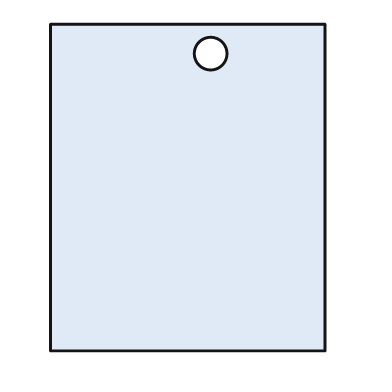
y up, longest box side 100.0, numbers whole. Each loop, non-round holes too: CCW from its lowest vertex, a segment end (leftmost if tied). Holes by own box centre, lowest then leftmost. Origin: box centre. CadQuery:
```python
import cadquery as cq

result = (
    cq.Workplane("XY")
    .moveTo(-42.0, -50.0)
    .lineTo(42.0, -50.0)
    .lineTo(42.0, 50.0)
    .lineTo(-42.0, 50.0)
    .close()
    .moveTo(7.0, 41.0)
    .circle(5.0)
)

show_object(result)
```